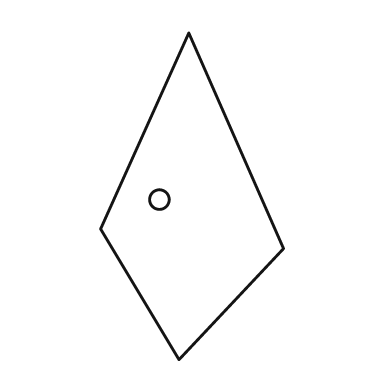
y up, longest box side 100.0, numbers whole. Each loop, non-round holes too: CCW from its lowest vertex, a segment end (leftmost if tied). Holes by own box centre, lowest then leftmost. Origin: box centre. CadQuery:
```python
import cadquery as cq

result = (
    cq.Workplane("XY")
    .moveTo(-4.0, -50.0)
    .lineTo(28.0, -16.0)
    .lineTo(-1.0, 50.0)
    .lineTo(-28.0, -10.0)
    .close()
    .moveTo(-10.0, -1.0)
    .circle(3.0)
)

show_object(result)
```